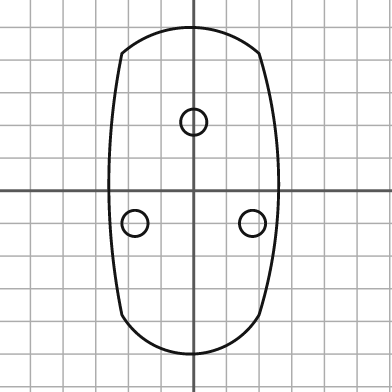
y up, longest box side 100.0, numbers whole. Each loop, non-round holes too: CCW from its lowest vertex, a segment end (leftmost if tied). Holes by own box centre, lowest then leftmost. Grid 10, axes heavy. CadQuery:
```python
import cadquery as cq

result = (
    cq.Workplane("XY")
    .moveTo(-22.0, -38.0)
    .threePointArc((-1.0, -50.0), (20.0, -38.0))
    .threePointArc((26.0, 2.0), (20.0, 42.0))
    .threePointArc((-1.0, 50.0), (-22.0, 42.0))
    .threePointArc((-26.0, 2.0), (-22.0, -38.0))
    .close()
    .moveTo(-18.0, -10.0)
    .circle(4.0)
    .moveTo(18.0, -10.0)
    .circle(4.0)
    .moveTo(0.0, 21.0)
    .circle(4.0)
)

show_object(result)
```